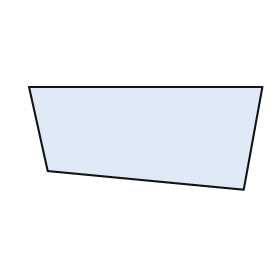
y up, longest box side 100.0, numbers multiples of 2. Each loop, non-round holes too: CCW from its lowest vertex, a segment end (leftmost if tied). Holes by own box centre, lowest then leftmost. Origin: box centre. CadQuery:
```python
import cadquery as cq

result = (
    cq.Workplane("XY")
    .moveTo(42.0, -22.0)
    .lineTo(50.0, 22.0)
    .lineTo(-50.0, 22.0)
    .lineTo(-42.0, -14.0)
    .close()
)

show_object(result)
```